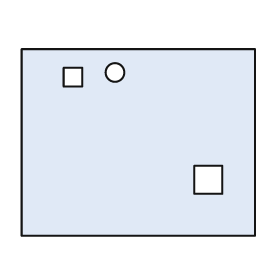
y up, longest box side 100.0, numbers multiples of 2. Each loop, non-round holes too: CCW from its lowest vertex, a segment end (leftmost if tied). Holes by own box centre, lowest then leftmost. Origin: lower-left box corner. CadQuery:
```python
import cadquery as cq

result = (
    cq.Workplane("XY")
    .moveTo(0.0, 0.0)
    .lineTo(100.0, 0.0)
    .lineTo(100.0, 80.0)
    .lineTo(0.0, 80.0)
    .close()
    .moveTo(74.0, 18.0)
    .lineTo(86.0, 18.0)
    .lineTo(86.0, 30.0)
    .lineTo(74.0, 30.0)
    .close()
    .moveTo(18.0, 64.0)
    .lineTo(26.0, 64.0)
    .lineTo(26.0, 72.0)
    .lineTo(18.0, 72.0)
    .close()
    .moveTo(40.0, 70.0)
    .circle(4.0)
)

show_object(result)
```